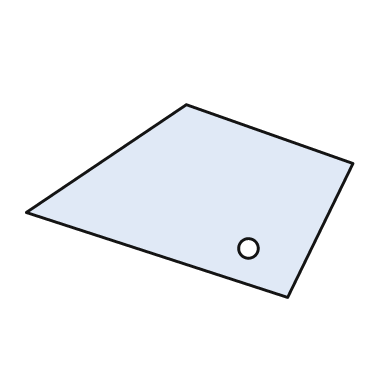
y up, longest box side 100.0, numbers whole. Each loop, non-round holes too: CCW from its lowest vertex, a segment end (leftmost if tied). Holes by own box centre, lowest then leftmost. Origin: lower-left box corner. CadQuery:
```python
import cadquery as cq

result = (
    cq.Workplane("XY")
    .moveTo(80.0, 0.0)
    .lineTo(100.0, 41.0)
    .lineTo(49.0, 59.0)
    .lineTo(0.0, 26.0)
    .close()
    .moveTo(68.0, 15.0)
    .circle(3.0)
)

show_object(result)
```